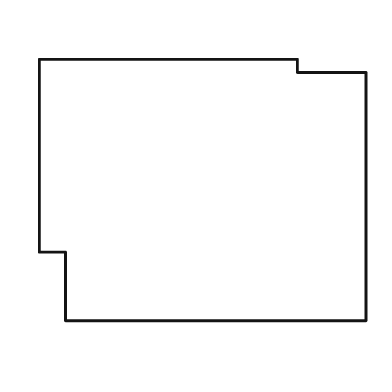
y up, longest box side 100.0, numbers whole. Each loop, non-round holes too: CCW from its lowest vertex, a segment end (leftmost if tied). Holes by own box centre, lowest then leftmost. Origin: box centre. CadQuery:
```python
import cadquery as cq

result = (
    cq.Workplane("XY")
    .moveTo(-42.0, -40.0)
    .lineTo(50.0, -40.0)
    .lineTo(50.0, 36.0)
    .lineTo(29.0, 36.0)
    .lineTo(29.0, 40.0)
    .lineTo(-50.0, 40.0)
    .lineTo(-50.0, -19.0)
    .lineTo(-42.0, -19.0)
    .close()
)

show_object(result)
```